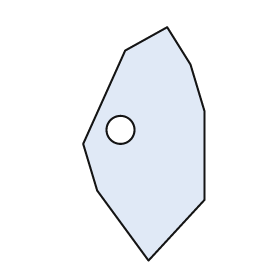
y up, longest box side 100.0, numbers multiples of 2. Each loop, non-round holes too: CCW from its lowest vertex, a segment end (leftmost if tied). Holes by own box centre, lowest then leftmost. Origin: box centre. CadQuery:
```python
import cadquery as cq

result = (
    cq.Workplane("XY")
    .moveTo(2.0, -50.0)
    .lineTo(26.0, -24.0)
    .lineTo(26.0, 14.0)
    .lineTo(20.0, 34.0)
    .lineTo(10.0, 50.0)
    .lineTo(-8.0, 40.0)
    .lineTo(-26.0, 0.0)
    .lineTo(-20.0, -20.0)
    .close()
    .moveTo(-10.0, 6.0)
    .circle(6.0)
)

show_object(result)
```